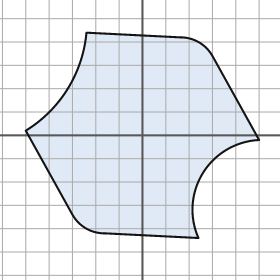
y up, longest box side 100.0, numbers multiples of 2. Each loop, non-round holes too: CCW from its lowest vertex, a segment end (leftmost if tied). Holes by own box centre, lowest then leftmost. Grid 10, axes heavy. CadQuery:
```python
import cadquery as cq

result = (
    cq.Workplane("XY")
    .moveTo(24.0, -44.0)
    .threePointArc((26.0, -16.0), (50.0, -2.0))
    .lineTo(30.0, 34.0)
    .threePointArc((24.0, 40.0), (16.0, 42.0))
    .lineTo(-24.0, 44.0)
    .threePointArc((-32.0, 20.0), (-50.0, 2.0))
    .lineTo(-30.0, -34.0)
    .threePointArc((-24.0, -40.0), (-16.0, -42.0))
    .close()
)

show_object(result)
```